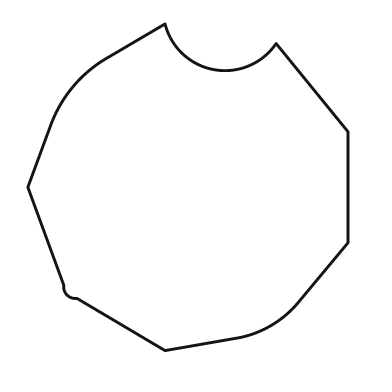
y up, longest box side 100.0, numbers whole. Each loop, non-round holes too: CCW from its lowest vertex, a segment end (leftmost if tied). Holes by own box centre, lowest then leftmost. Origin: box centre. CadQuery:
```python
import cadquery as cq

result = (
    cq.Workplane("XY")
    .moveTo(-7.0, -50.0)
    .lineTo(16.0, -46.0)
    .threePointArc((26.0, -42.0), (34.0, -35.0))
    .lineTo(49.0, -17.0)
    .lineTo(49.0, 17.0)
    .lineTo(27.0, 44.0)
    .threePointArc((8.0, 36.0), (-7.0, 50.0))
    .lineTo(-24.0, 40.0)
    .threePointArc((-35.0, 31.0), (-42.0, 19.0))
    .lineTo(-49.0, 0.0)
    .lineTo(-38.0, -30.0)
    .threePointArc((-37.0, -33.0), (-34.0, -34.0))
    .close()
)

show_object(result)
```